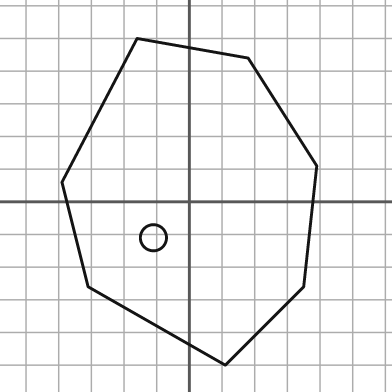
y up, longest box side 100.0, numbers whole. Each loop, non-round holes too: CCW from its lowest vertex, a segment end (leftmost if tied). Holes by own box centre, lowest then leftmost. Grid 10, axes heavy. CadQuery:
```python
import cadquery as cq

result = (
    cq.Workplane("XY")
    .moveTo(11.0, -50.0)
    .lineTo(35.0, -26.0)
    .lineTo(39.0, 11.0)
    .lineTo(18.0, 44.0)
    .lineTo(-16.0, 50.0)
    .lineTo(-39.0, 6.0)
    .lineTo(-31.0, -26.0)
    .close()
    .moveTo(-11.0, -11.0)
    .circle(4.0)
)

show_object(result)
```